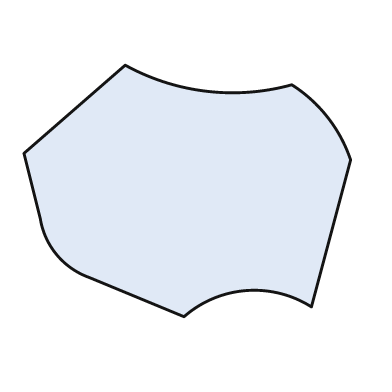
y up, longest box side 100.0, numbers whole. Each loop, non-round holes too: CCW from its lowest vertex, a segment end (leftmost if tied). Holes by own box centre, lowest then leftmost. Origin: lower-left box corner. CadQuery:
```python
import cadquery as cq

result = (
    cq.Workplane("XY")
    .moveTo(49.0, 0.0)
    .threePointArc((68.0, 8.0), (88.0, 3.0))
    .lineTo(100.0, 48.0)
    .threePointArc((93.0, 61.0), (82.0, 71.0))
    .threePointArc((56.0, 69.0), (31.0, 77.0))
    .lineTo(0.0, 50.0)
    .lineTo(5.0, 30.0)
    .threePointArc((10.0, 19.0), (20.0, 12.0))
    .close()
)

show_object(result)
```